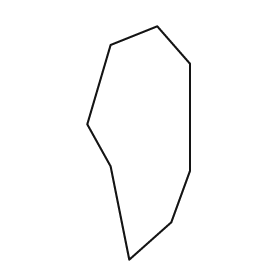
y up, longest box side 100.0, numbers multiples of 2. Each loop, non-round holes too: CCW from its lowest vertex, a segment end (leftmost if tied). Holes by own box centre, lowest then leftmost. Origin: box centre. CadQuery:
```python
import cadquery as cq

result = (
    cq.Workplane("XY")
    .moveTo(-4.0, -50.0)
    .lineTo(14.0, -34.0)
    .lineTo(22.0, -12.0)
    .lineTo(22.0, 34.0)
    .lineTo(8.0, 50.0)
    .lineTo(-12.0, 42.0)
    .lineTo(-22.0, 8.0)
    .lineTo(-12.0, -10.0)
    .close()
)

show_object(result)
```